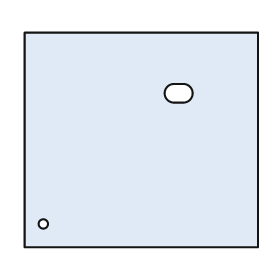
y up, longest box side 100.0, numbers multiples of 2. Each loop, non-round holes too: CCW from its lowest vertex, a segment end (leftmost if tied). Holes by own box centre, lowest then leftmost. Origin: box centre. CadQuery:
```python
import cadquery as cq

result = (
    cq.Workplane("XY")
    .moveTo(-50.0, -46.0)
    .lineTo(50.0, -46.0)
    .lineTo(50.0, 46.0)
    .lineTo(-50.0, 46.0)
    .close()
    .moveTo(-42.0, -36.0)
    .circle(2.0)
    .moveTo(14.0, 16.0)
    .lineTo(18.0, 16.0)
    .threePointArc((22.0, 20.0), (18.0, 24.0))
    .lineTo(14.0, 24.0)
    .threePointArc((10.0, 20.0), (14.0, 16.0))
    .close()
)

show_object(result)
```